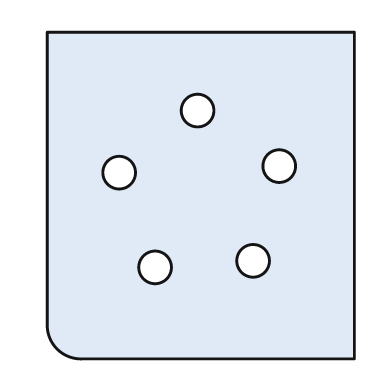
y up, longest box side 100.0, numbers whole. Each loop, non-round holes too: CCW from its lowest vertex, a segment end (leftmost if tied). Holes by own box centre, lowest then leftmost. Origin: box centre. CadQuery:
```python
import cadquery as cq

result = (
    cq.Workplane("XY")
    .moveTo(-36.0, -50.0)
    .lineTo(47.0, -50.0)
    .lineTo(47.0, 50.0)
    .lineTo(-47.0, 50.0)
    .lineTo(-47.0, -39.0)
    .threePointArc((-44.0, -47.0), (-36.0, -50.0))
    .close()
    .moveTo(-14.0, -22.0)
    .circle(5.0)
    .moveTo(16.0, -20.0)
    .circle(5.0)
    .moveTo(-25.0, 7.0)
    .circle(5.0)
    .moveTo(24.0, 9.0)
    .circle(5.0)
    .moveTo(-1.0, 26.0)
    .circle(5.0)
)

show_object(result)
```